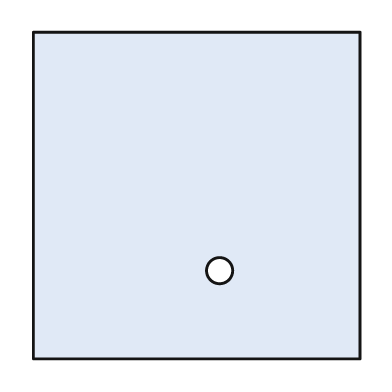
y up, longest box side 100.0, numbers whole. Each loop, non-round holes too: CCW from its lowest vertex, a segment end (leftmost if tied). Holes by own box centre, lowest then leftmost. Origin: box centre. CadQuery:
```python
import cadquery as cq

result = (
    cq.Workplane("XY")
    .moveTo(-50.0, -50.0)
    .lineTo(50.0, -50.0)
    .lineTo(50.0, 50.0)
    .lineTo(-50.0, 50.0)
    .close()
    .moveTo(7.0, -23.0)
    .circle(4.0)
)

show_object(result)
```